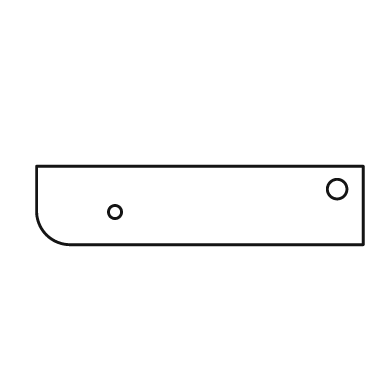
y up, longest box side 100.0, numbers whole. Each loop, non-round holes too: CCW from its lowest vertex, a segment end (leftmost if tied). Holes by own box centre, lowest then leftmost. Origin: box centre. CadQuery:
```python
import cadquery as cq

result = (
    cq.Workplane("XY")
    .moveTo(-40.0, -12.0)
    .lineTo(50.0, -12.0)
    .lineTo(50.0, 12.0)
    .lineTo(-50.0, 12.0)
    .lineTo(-50.0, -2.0)
    .threePointArc((-47.0, -9.0), (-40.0, -12.0))
    .close()
    .moveTo(-26.0, -2.0)
    .circle(2.0)
    .moveTo(42.0, 5.0)
    .circle(3.0)
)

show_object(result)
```